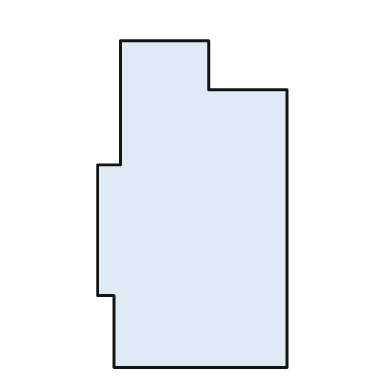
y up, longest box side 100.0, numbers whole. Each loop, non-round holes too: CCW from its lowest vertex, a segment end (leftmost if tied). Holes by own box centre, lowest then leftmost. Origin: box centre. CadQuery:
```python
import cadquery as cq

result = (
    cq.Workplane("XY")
    .moveTo(-24.0, -50.0)
    .lineTo(29.0, -50.0)
    .lineTo(29.0, 35.0)
    .lineTo(5.0, 35.0)
    .lineTo(5.0, 50.0)
    .lineTo(-22.0, 50.0)
    .lineTo(-22.0, 12.0)
    .lineTo(-29.0, 12.0)
    .lineTo(-29.0, -28.0)
    .lineTo(-24.0, -28.0)
    .close()
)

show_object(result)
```